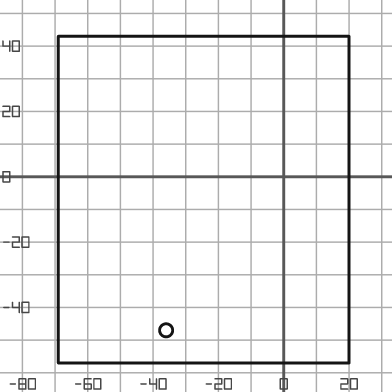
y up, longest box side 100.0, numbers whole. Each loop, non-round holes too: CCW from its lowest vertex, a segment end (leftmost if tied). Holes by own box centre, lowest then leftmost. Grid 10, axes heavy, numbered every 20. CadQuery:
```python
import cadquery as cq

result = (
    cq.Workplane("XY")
    .moveTo(-69.0, -57.0)
    .lineTo(20.0, -57.0)
    .lineTo(20.0, 43.0)
    .lineTo(-69.0, 43.0)
    .close()
    .moveTo(-36.0, -47.0)
    .circle(2.0)
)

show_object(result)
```